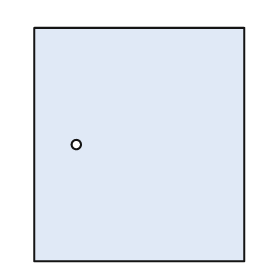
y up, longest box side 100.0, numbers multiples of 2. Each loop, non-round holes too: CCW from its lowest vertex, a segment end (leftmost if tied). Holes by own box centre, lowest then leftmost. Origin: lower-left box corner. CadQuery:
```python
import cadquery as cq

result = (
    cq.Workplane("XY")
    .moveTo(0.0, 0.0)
    .lineTo(90.0, 0.0)
    .lineTo(90.0, 100.0)
    .lineTo(0.0, 100.0)
    .close()
    .moveTo(18.0, 50.0)
    .circle(2.0)
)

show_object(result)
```